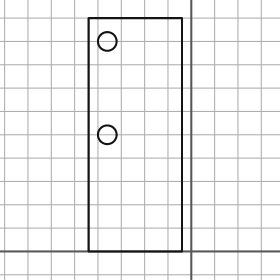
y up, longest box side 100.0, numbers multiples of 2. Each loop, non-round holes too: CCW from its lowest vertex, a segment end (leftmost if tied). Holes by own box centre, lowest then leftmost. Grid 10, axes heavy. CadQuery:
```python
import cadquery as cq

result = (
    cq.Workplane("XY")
    .moveTo(-44.0, 0.0)
    .lineTo(-4.0, 0.0)
    .lineTo(-4.0, 100.0)
    .lineTo(-44.0, 100.0)
    .close()
    .moveTo(-36.0, 50.0)
    .circle(4.0)
    .moveTo(-36.0, 90.0)
    .circle(4.0)
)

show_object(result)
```